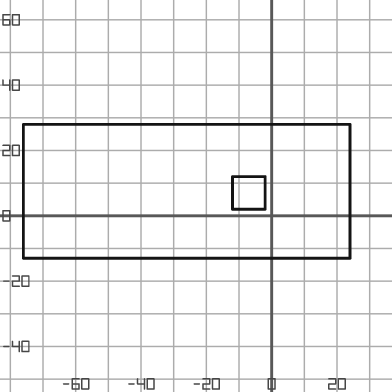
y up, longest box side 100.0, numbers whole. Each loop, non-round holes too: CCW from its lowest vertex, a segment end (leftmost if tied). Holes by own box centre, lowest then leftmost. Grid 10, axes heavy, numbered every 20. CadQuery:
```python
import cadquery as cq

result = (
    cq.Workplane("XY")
    .moveTo(-76.0, -13.0)
    .lineTo(24.0, -13.0)
    .lineTo(24.0, 28.0)
    .lineTo(-76.0, 28.0)
    .close()
    .moveTo(-12.0, 2.0)
    .lineTo(-2.0, 2.0)
    .lineTo(-2.0, 12.0)
    .lineTo(-12.0, 12.0)
    .close()
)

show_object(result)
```